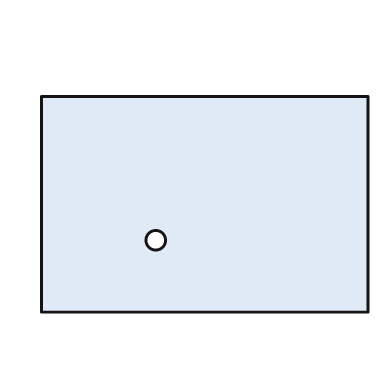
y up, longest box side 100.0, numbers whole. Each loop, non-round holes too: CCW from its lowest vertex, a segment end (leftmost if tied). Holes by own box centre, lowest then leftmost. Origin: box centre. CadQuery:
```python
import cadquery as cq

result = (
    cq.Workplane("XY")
    .moveTo(-50.0, -33.0)
    .lineTo(50.0, -33.0)
    .lineTo(50.0, 33.0)
    .lineTo(-50.0, 33.0)
    .close()
    .moveTo(-15.0, -11.0)
    .circle(3.0)
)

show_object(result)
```